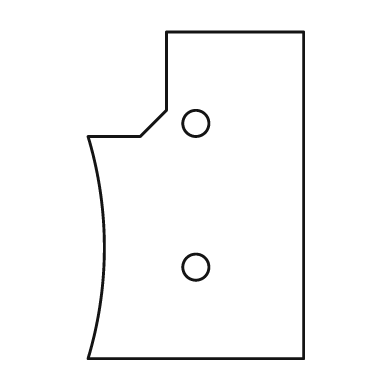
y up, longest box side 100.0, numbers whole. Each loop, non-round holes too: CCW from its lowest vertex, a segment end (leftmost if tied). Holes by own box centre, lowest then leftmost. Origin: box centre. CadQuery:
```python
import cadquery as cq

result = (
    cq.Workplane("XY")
    .moveTo(-33.0, -50.0)
    .lineTo(33.0, -50.0)
    .lineTo(33.0, 50.0)
    .lineTo(-9.0, 50.0)
    .lineTo(-9.0, 26.0)
    .lineTo(-17.0, 18.0)
    .lineTo(-33.0, 18.0)
    .threePointArc((-28.0, -16.0), (-33.0, -50.0))
    .close()
    .moveTo(0.0, -22.0)
    .circle(4.0)
    .moveTo(0.0, 22.0)
    .circle(4.0)
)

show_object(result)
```